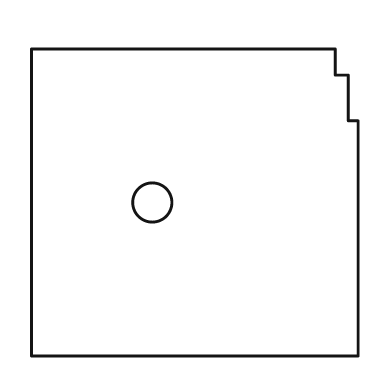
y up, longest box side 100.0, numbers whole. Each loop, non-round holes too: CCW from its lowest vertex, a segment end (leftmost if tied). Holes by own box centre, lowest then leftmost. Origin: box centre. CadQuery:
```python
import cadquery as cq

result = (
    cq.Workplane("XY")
    .moveTo(-50.0, -47.0)
    .lineTo(50.0, -47.0)
    .lineTo(50.0, 25.0)
    .lineTo(47.0, 25.0)
    .lineTo(47.0, 39.0)
    .lineTo(43.0, 39.0)
    .lineTo(43.0, 47.0)
    .lineTo(-50.0, 47.0)
    .close()
    .moveTo(-13.0, 0.0)
    .circle(6.0)
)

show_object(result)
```